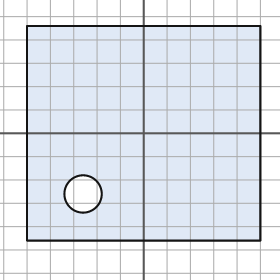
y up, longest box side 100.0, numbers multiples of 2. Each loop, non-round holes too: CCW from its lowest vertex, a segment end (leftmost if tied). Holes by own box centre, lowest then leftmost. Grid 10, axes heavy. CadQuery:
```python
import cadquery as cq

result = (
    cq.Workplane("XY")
    .moveTo(-50.0, -46.0)
    .lineTo(50.0, -46.0)
    .lineTo(50.0, 46.0)
    .lineTo(-50.0, 46.0)
    .close()
    .moveTo(-26.0, -26.0)
    .circle(8.0)
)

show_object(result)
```